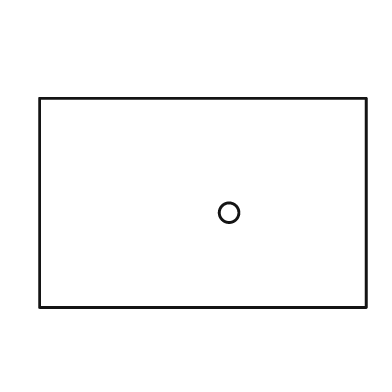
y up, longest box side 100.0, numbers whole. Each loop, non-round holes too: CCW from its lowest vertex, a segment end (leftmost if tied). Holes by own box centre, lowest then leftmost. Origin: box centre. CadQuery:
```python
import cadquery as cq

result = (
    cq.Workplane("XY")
    .moveTo(-50.0, -32.0)
    .lineTo(50.0, -32.0)
    .lineTo(50.0, 32.0)
    .lineTo(-50.0, 32.0)
    .close()
    .moveTo(8.0, -3.0)
    .circle(3.0)
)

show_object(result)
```